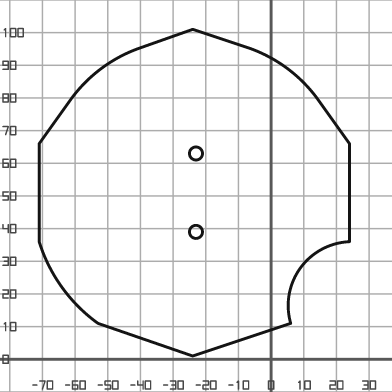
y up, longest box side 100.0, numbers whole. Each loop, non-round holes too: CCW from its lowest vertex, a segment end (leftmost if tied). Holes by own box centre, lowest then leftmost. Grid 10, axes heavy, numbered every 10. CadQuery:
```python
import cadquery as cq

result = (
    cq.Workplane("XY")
    .moveTo(-24.0, 1.0)
    .lineTo(6.0, 11.0)
    .threePointArc((9.0, 28.0), (24.0, 36.0))
    .lineTo(24.0, 66.0)
    .lineTo(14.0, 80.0)
    .threePointArc((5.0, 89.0), (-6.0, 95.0))
    .lineTo(-24.0, 101.0)
    .lineTo(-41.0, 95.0)
    .threePointArc((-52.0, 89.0), (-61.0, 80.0))
    .lineTo(-71.0, 66.0)
    .lineTo(-71.0, 36.0)
    .threePointArc((-64.0, 22.0), (-53.0, 11.0))
    .close()
    .moveTo(-23.0, 39.0)
    .circle(2.0)
    .moveTo(-23.0, 63.0)
    .circle(2.0)
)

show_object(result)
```